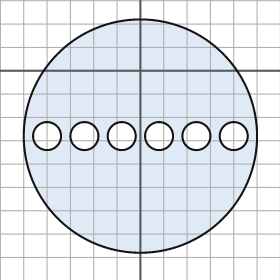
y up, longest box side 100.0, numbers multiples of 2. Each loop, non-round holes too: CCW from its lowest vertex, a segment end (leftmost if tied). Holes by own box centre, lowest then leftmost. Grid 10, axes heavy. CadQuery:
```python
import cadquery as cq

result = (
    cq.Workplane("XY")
    .moveTo(0.0, -28.0)
    .circle(50.0)
    .moveTo(-40.0, -28.0)
    .circle(6.0)
    .moveTo(-24.0, -28.0)
    .circle(6.0)
    .moveTo(-8.0, -28.0)
    .circle(6.0)
    .moveTo(8.0, -28.0)
    .circle(6.0)
    .moveTo(24.0, -28.0)
    .circle(6.0)
    .moveTo(40.0, -28.0)
    .circle(6.0)
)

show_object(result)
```